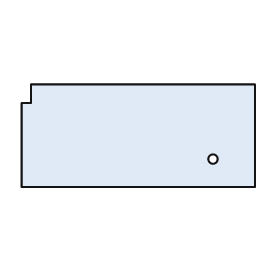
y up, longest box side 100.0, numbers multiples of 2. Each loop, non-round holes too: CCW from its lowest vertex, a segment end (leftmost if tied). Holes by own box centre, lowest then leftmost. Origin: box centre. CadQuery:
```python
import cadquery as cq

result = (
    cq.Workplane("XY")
    .moveTo(-50.0, -22.0)
    .lineTo(50.0, -22.0)
    .lineTo(50.0, 22.0)
    .lineTo(-46.0, 22.0)
    .lineTo(-46.0, 14.0)
    .lineTo(-50.0, 14.0)
    .close()
    .moveTo(32.0, -10.0)
    .circle(2.0)
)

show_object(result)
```